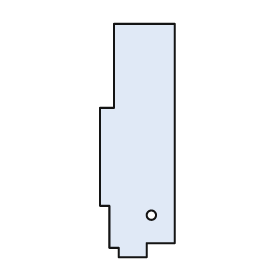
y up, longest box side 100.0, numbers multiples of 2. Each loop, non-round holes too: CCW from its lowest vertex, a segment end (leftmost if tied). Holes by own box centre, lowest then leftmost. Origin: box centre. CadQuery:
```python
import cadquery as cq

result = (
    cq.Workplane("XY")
    .moveTo(-8.0, -50.0)
    .lineTo(4.0, -50.0)
    .lineTo(4.0, -44.0)
    .lineTo(16.0, -44.0)
    .lineTo(16.0, 50.0)
    .lineTo(-10.0, 50.0)
    .lineTo(-10.0, 14.0)
    .lineTo(-16.0, 14.0)
    .lineTo(-16.0, -28.0)
    .lineTo(-12.0, -28.0)
    .lineTo(-12.0, -46.0)
    .lineTo(-8.0, -46.0)
    .close()
    .moveTo(6.0, -32.0)
    .circle(2.0)
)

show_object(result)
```